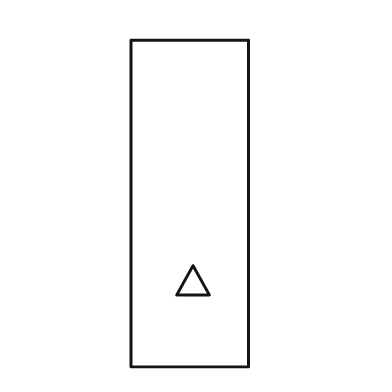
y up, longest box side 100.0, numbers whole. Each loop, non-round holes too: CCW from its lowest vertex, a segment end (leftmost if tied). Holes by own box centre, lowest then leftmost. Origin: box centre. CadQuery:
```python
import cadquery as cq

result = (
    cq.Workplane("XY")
    .moveTo(-18.0, -50.0)
    .lineTo(18.0, -50.0)
    .lineTo(18.0, 50.0)
    .lineTo(-18.0, 50.0)
    .close()
    .moveTo(-4.0, -28.0)
    .lineTo(6.0, -28.0)
    .lineTo(1.0, -19.0)
    .close()
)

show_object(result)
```